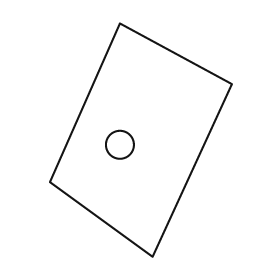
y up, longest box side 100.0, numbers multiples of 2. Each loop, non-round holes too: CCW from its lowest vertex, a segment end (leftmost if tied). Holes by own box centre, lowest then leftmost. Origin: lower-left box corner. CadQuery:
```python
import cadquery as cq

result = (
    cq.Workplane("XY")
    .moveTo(44.0, 0.0)
    .lineTo(78.0, 74.0)
    .lineTo(30.0, 100.0)
    .lineTo(0.0, 32.0)
    .close()
    .moveTo(30.0, 48.0)
    .circle(6.0)
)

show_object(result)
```